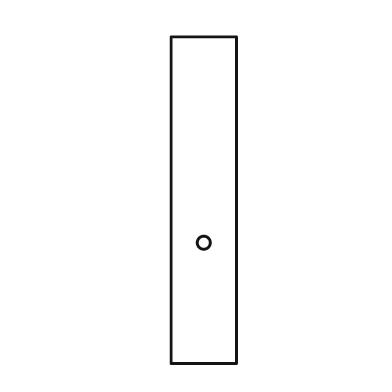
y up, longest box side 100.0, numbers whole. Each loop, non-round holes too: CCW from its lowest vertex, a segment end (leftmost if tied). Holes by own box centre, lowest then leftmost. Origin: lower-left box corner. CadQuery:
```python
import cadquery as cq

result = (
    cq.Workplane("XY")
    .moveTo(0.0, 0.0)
    .lineTo(20.0, 0.0)
    .lineTo(20.0, 100.0)
    .lineTo(0.0, 100.0)
    .close()
    .moveTo(10.0, 37.0)
    .circle(2.0)
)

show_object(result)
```